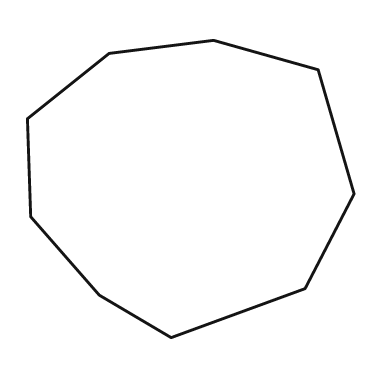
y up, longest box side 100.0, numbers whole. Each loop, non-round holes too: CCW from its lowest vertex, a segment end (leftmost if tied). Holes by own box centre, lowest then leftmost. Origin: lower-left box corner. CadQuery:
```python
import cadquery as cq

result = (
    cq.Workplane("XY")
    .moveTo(44.0, 0.0)
    .lineTo(85.0, 15.0)
    .lineTo(100.0, 44.0)
    .lineTo(89.0, 82.0)
    .lineTo(57.0, 91.0)
    .lineTo(25.0, 87.0)
    .lineTo(0.0, 67.0)
    .lineTo(1.0, 37.0)
    .lineTo(22.0, 13.0)
    .close()
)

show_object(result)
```